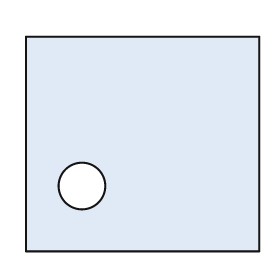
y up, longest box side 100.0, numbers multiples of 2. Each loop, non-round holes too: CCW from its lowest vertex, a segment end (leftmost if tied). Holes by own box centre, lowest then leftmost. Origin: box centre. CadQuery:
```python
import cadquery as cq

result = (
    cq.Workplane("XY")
    .moveTo(-50.0, -46.0)
    .lineTo(50.0, -46.0)
    .lineTo(50.0, 46.0)
    .lineTo(-50.0, 46.0)
    .close()
    .moveTo(-26.0, -18.0)
    .circle(10.0)
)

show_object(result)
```